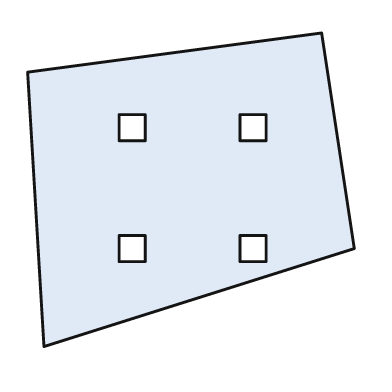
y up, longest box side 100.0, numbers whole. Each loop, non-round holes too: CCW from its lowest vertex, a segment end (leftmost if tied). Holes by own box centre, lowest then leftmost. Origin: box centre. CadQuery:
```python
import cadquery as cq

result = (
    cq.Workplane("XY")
    .moveTo(-45.0, -48.0)
    .lineTo(50.0, -18.0)
    .lineTo(40.0, 48.0)
    .lineTo(-50.0, 36.0)
    .close()
    .moveTo(-22.0, -22.0)
    .lineTo(-14.0, -22.0)
    .lineTo(-14.0, -14.0)
    .lineTo(-22.0, -14.0)
    .close()
    .moveTo(15.0, -22.0)
    .lineTo(23.0, -22.0)
    .lineTo(23.0, -14.0)
    .lineTo(15.0, -14.0)
    .close()
    .moveTo(-22.0, 15.0)
    .lineTo(-14.0, 15.0)
    .lineTo(-14.0, 23.0)
    .lineTo(-22.0, 23.0)
    .close()
    .moveTo(15.0, 15.0)
    .lineTo(23.0, 15.0)
    .lineTo(23.0, 23.0)
    .lineTo(15.0, 23.0)
    .close()
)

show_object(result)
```